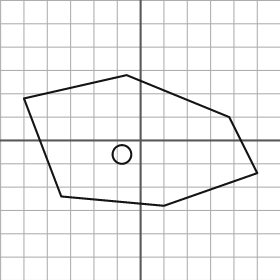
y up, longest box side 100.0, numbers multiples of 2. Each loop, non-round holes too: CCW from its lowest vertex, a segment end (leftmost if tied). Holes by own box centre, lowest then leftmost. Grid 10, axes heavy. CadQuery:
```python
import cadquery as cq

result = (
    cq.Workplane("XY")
    .moveTo(10.0, -28.0)
    .lineTo(50.0, -14.0)
    .lineTo(38.0, 10.0)
    .lineTo(-6.0, 28.0)
    .lineTo(-50.0, 18.0)
    .lineTo(-34.0, -24.0)
    .close()
    .moveTo(-8.0, -6.0)
    .circle(4.0)
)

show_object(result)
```